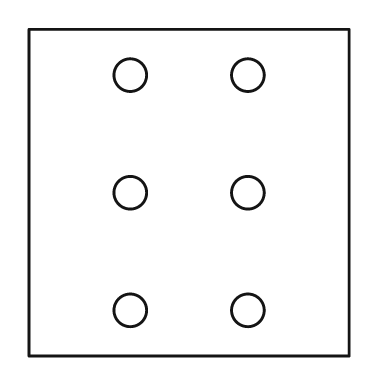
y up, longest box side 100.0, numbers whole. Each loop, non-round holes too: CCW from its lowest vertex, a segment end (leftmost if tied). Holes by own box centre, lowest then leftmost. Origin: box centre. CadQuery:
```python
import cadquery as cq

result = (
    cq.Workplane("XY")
    .moveTo(-49.0, -50.0)
    .lineTo(49.0, -50.0)
    .lineTo(49.0, 50.0)
    .lineTo(-49.0, 50.0)
    .close()
    .moveTo(-18.0, -36.0)
    .circle(5.0)
    .moveTo(18.0, -36.0)
    .circle(5.0)
    .moveTo(-18.0, 0.0)
    .circle(5.0)
    .moveTo(18.0, 0.0)
    .circle(5.0)
    .moveTo(-18.0, 36.0)
    .circle(5.0)
    .moveTo(18.0, 36.0)
    .circle(5.0)
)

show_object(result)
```